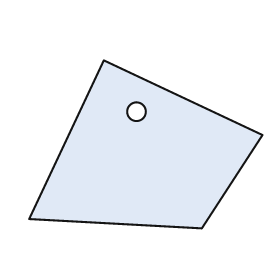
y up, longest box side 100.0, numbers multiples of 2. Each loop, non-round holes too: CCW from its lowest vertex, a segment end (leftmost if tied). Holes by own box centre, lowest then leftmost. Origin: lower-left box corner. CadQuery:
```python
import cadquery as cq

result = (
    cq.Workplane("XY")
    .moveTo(74.0, 0.0)
    .lineTo(100.0, 40.0)
    .lineTo(32.0, 72.0)
    .lineTo(0.0, 4.0)
    .close()
    .moveTo(46.0, 50.0)
    .circle(4.0)
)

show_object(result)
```